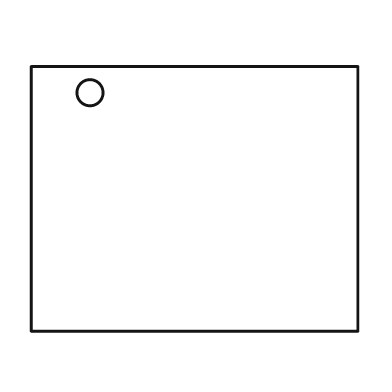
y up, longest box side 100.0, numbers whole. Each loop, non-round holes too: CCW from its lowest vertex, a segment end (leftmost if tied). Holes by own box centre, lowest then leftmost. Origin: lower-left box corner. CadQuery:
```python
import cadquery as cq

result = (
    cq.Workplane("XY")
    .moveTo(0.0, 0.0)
    .lineTo(100.0, 0.0)
    .lineTo(100.0, 81.0)
    .lineTo(0.0, 81.0)
    .close()
    .moveTo(18.0, 73.0)
    .circle(4.0)
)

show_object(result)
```